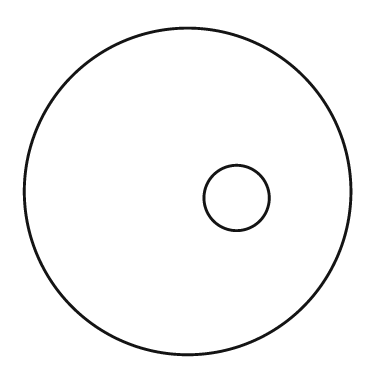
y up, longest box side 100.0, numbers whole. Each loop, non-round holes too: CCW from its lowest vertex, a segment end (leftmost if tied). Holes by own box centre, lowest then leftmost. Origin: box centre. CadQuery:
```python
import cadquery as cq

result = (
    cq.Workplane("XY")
    .moveTo(0.0, 0.0)
    .circle(50.0)
    .moveTo(15.0, -2.0)
    .circle(10.0)
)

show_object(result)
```